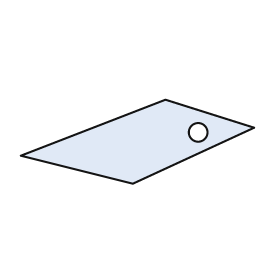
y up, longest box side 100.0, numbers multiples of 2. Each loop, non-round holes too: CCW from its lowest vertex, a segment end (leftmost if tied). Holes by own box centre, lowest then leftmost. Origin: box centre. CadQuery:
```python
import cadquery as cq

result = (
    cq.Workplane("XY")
    .moveTo(-2.0, -18.0)
    .lineTo(50.0, 6.0)
    .lineTo(12.0, 18.0)
    .lineTo(-50.0, -6.0)
    .close()
    .moveTo(26.0, 4.0)
    .circle(4.0)
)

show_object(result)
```